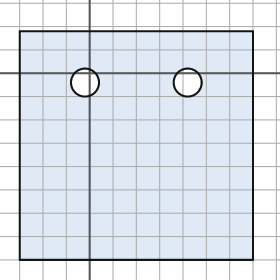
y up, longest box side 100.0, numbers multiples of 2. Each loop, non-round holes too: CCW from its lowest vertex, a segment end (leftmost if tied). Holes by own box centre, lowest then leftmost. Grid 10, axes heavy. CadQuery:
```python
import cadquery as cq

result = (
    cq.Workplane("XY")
    .moveTo(-30.0, -80.0)
    .lineTo(70.0, -80.0)
    .lineTo(70.0, 18.0)
    .lineTo(-30.0, 18.0)
    .close()
    .moveTo(-2.0, -4.0)
    .circle(6.0)
    .moveTo(42.0, -4.0)
    .circle(6.0)
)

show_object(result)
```